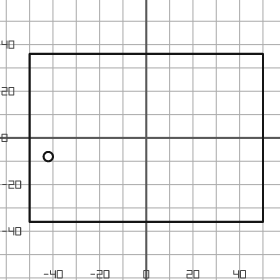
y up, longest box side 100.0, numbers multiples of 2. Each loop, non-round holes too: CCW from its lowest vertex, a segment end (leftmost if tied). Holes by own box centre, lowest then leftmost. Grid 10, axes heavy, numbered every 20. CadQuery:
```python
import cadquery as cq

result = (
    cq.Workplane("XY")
    .moveTo(-50.0, -36.0)
    .lineTo(50.0, -36.0)
    .lineTo(50.0, 36.0)
    .lineTo(-50.0, 36.0)
    .close()
    .moveTo(-42.0, -8.0)
    .circle(2.0)
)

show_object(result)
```